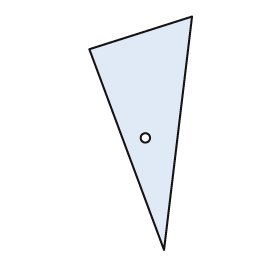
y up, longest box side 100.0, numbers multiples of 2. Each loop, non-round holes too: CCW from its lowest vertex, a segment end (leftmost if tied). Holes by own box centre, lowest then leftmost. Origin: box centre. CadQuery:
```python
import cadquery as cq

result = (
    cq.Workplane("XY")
    .moveTo(10.0, -50.0)
    .lineTo(22.0, 50.0)
    .lineTo(-22.0, 36.0)
    .close()
    .moveTo(2.0, -2.0)
    .circle(2.0)
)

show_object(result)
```